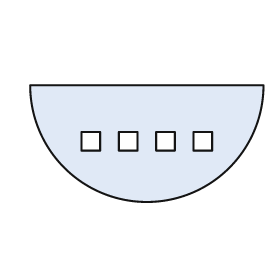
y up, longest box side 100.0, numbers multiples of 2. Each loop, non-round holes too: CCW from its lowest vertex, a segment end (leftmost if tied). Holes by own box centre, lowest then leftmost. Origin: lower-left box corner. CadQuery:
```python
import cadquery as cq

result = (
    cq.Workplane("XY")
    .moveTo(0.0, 50.0)
    .threePointArc((50.0, 0.0), (100.0, 50.0))
    .close()
    .moveTo(22.0, 22.0)
    .lineTo(30.0, 22.0)
    .lineTo(30.0, 30.0)
    .lineTo(22.0, 30.0)
    .close()
    .moveTo(38.0, 22.0)
    .lineTo(46.0, 22.0)
    .lineTo(46.0, 30.0)
    .lineTo(38.0, 30.0)
    .close()
    .moveTo(54.0, 22.0)
    .lineTo(62.0, 22.0)
    .lineTo(62.0, 30.0)
    .lineTo(54.0, 30.0)
    .close()
    .moveTo(70.0, 22.0)
    .lineTo(78.0, 22.0)
    .lineTo(78.0, 30.0)
    .lineTo(70.0, 30.0)
    .close()
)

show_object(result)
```